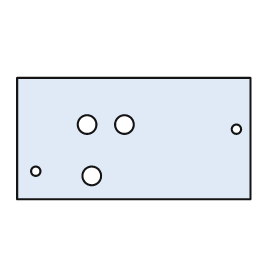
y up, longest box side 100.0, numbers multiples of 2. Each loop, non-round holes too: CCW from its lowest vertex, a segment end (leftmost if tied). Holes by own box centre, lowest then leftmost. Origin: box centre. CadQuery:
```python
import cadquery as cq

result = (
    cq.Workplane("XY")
    .moveTo(-50.0, -26.0)
    .lineTo(50.0, -26.0)
    .lineTo(50.0, 26.0)
    .lineTo(-50.0, 26.0)
    .close()
    .moveTo(-18.0, -16.0)
    .circle(4.0)
    .moveTo(-42.0, -14.0)
    .circle(2.0)
    .moveTo(44.0, 4.0)
    .circle(2.0)
    .moveTo(-20.0, 6.0)
    .circle(4.0)
    .moveTo(-4.0, 6.0)
    .circle(4.0)
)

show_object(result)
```